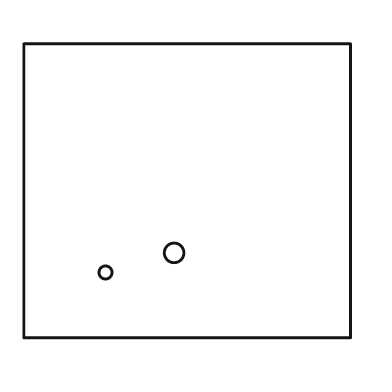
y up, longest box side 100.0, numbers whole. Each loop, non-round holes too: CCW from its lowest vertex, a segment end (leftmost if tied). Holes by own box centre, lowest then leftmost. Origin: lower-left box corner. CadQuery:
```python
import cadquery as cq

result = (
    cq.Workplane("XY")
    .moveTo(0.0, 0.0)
    .lineTo(100.0, 0.0)
    .lineTo(100.0, 90.0)
    .lineTo(0.0, 90.0)
    .close()
    .moveTo(25.0, 20.0)
    .circle(2.0)
    .moveTo(46.0, 26.0)
    .circle(3.0)
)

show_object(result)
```